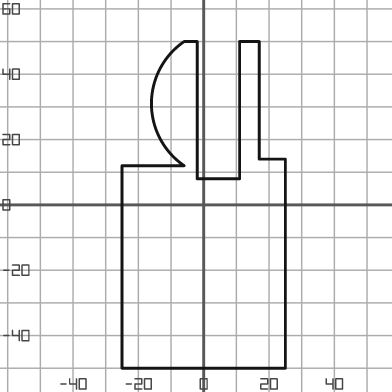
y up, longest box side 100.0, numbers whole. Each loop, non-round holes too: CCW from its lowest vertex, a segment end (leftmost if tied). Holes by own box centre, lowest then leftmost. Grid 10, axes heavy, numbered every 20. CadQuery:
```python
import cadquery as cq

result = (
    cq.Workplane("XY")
    .moveTo(-25.0, -50.0)
    .lineTo(25.0, -50.0)
    .lineTo(25.0, 14.0)
    .lineTo(17.0, 14.0)
    .lineTo(17.0, 50.0)
    .lineTo(11.0, 50.0)
    .lineTo(11.0, 8.0)
    .lineTo(-2.0, 8.0)
    .lineTo(-2.0, 50.0)
    .lineTo(-6.0, 50.0)
    .threePointArc((-16.0, 31.0), (-6.0, 12.0))
    .lineTo(-25.0, 12.0)
    .close()
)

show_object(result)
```